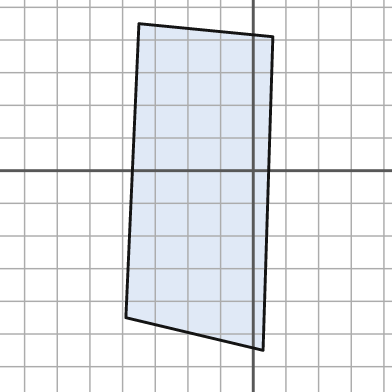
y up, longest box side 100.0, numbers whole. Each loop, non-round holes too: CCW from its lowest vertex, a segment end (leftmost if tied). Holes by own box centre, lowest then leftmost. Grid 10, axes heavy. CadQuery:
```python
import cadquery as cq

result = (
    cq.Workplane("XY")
    .moveTo(3.0, -55.0)
    .lineTo(6.0, 41.0)
    .lineTo(-35.0, 45.0)
    .lineTo(-39.0, -45.0)
    .close()
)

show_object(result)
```